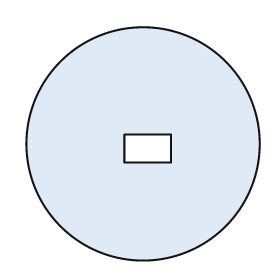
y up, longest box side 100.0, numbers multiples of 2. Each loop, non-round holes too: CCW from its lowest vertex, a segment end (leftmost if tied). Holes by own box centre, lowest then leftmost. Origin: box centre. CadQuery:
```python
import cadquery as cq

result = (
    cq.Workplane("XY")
    .moveTo(0.0, 0.0)
    .circle(50.0)
    .moveTo(-8.0, -8.0)
    .lineTo(12.0, -8.0)
    .lineTo(12.0, 4.0)
    .lineTo(-8.0, 4.0)
    .close()
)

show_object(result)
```